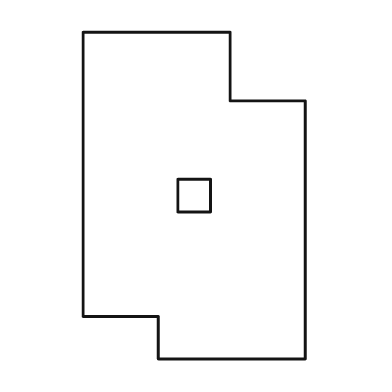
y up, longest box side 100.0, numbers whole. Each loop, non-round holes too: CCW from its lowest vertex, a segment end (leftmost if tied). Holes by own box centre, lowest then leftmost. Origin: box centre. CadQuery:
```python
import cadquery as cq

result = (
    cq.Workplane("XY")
    .moveTo(-11.0, -50.0)
    .lineTo(34.0, -50.0)
    .lineTo(34.0, 29.0)
    .lineTo(11.0, 29.0)
    .lineTo(11.0, 50.0)
    .lineTo(-34.0, 50.0)
    .lineTo(-34.0, -37.0)
    .lineTo(-11.0, -37.0)
    .close()
    .moveTo(-5.0, -5.0)
    .lineTo(5.0, -5.0)
    .lineTo(5.0, 5.0)
    .lineTo(-5.0, 5.0)
    .close()
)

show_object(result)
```